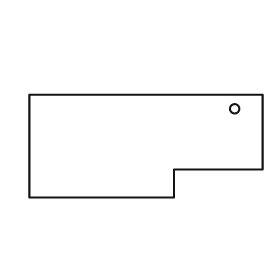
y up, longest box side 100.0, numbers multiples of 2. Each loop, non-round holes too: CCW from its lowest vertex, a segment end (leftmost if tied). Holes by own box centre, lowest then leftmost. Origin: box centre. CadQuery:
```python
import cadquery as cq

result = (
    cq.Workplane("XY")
    .moveTo(-50.0, -22.0)
    .lineTo(12.0, -22.0)
    .lineTo(12.0, -10.0)
    .lineTo(50.0, -10.0)
    .lineTo(50.0, 22.0)
    .lineTo(-50.0, 22.0)
    .close()
    .moveTo(38.0, 16.0)
    .circle(2.0)
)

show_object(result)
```